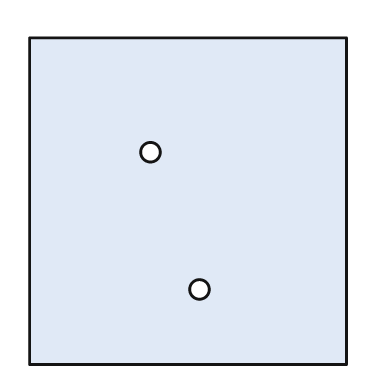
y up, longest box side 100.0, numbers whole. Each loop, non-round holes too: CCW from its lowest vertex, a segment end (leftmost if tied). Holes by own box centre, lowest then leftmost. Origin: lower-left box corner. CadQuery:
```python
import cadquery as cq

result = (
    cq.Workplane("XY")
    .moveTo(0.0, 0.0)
    .lineTo(97.0, 0.0)
    .lineTo(97.0, 100.0)
    .lineTo(0.0, 100.0)
    .close()
    .moveTo(52.0, 23.0)
    .circle(3.0)
    .moveTo(37.0, 65.0)
    .circle(3.0)
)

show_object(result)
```